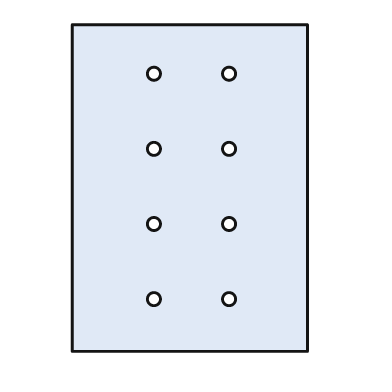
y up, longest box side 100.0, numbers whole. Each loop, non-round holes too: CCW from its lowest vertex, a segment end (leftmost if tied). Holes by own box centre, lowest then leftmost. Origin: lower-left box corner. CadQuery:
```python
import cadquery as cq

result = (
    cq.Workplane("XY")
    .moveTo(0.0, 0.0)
    .lineTo(72.0, 0.0)
    .lineTo(72.0, 100.0)
    .lineTo(0.0, 100.0)
    .close()
    .moveTo(25.0, 16.0)
    .circle(2.0)
    .moveTo(48.0, 16.0)
    .circle(2.0)
    .moveTo(25.0, 39.0)
    .circle(2.0)
    .moveTo(48.0, 39.0)
    .circle(2.0)
    .moveTo(25.0, 62.0)
    .circle(2.0)
    .moveTo(48.0, 62.0)
    .circle(2.0)
    .moveTo(25.0, 85.0)
    .circle(2.0)
    .moveTo(48.0, 85.0)
    .circle(2.0)
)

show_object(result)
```